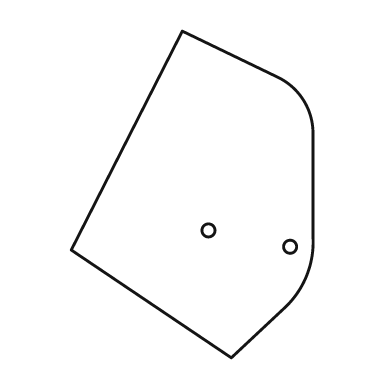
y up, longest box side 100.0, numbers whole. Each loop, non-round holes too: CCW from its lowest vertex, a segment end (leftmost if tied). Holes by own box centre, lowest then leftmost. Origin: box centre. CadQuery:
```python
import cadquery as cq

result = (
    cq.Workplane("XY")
    .moveTo(12.0, -50.0)
    .lineTo(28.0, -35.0)
    .threePointArc((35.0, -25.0), (37.0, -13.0))
    .lineTo(37.0, 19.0)
    .threePointArc((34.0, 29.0), (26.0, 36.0))
    .lineTo(-3.0, 50.0)
    .lineTo(-37.0, -17.0)
    .close()
    .moveTo(30.0, -16.0)
    .circle(2.0)
    .moveTo(5.0, -11.0)
    .circle(2.0)
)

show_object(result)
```